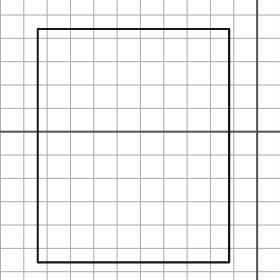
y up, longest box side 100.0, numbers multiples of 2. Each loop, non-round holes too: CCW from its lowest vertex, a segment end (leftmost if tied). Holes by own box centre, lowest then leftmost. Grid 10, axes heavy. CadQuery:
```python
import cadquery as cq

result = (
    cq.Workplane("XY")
    .moveTo(-94.0, -56.0)
    .lineTo(-12.0, -56.0)
    .lineTo(-12.0, 44.0)
    .lineTo(-94.0, 44.0)
    .close()
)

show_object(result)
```